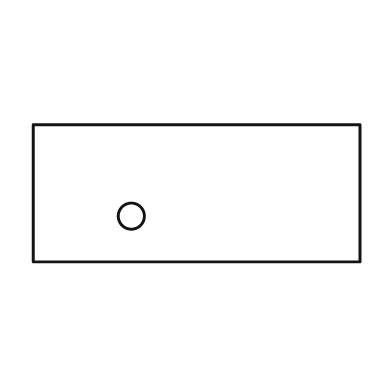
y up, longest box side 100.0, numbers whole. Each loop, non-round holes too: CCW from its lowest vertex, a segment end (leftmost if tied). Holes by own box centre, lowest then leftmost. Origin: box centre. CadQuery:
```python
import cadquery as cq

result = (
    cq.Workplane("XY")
    .moveTo(-50.0, -21.0)
    .lineTo(50.0, -21.0)
    .lineTo(50.0, 21.0)
    .lineTo(-50.0, 21.0)
    .close()
    .moveTo(-20.0, -7.0)
    .circle(4.0)
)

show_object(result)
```